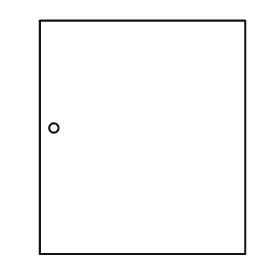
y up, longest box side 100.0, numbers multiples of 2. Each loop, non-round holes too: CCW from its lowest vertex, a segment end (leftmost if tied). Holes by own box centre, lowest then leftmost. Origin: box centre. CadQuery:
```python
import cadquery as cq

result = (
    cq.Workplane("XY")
    .moveTo(-44.0, -50.0)
    .lineTo(44.0, -50.0)
    .lineTo(44.0, 50.0)
    .lineTo(-44.0, 50.0)
    .close()
    .moveTo(-38.0, 4.0)
    .circle(2.0)
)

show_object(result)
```